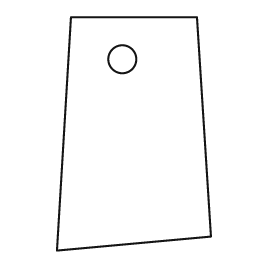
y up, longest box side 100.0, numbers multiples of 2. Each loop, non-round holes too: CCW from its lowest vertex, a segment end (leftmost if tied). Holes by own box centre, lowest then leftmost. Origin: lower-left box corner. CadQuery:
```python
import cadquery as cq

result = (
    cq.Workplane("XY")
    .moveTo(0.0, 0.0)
    .lineTo(66.0, 6.0)
    .lineTo(60.0, 100.0)
    .lineTo(6.0, 100.0)
    .close()
    .moveTo(28.0, 82.0)
    .circle(6.0)
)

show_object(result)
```